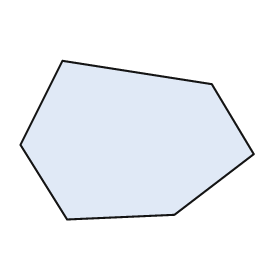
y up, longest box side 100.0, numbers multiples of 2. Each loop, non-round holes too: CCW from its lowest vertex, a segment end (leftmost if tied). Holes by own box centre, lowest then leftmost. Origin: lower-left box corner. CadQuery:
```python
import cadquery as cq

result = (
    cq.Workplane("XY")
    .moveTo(20.0, 0.0)
    .lineTo(66.0, 2.0)
    .lineTo(100.0, 28.0)
    .lineTo(82.0, 58.0)
    .lineTo(18.0, 68.0)
    .lineTo(0.0, 32.0)
    .close()
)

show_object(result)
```